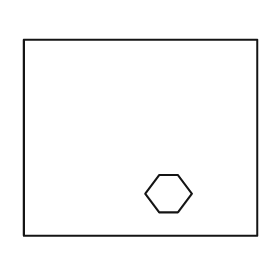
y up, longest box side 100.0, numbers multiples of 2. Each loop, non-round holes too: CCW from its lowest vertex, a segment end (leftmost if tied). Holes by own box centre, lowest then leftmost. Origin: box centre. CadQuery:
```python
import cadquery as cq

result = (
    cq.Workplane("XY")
    .moveTo(-50.0, -42.0)
    .lineTo(50.0, -42.0)
    .lineTo(50.0, 42.0)
    .lineTo(-50.0, 42.0)
    .close()
    .moveTo(8.0, -32.0)
    .lineTo(16.0, -32.0)
    .lineTo(22.0, -24.0)
    .lineTo(16.0, -16.0)
    .lineTo(8.0, -16.0)
    .lineTo(2.0, -24.0)
    .close()
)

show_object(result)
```